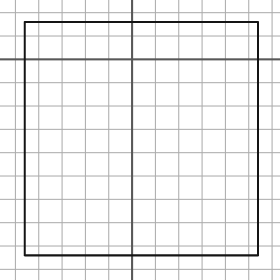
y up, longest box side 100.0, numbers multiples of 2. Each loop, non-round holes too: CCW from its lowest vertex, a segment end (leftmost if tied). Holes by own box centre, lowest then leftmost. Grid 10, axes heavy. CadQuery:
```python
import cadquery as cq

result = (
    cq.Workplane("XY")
    .moveTo(-46.0, -84.0)
    .lineTo(54.0, -84.0)
    .lineTo(54.0, 16.0)
    .lineTo(-46.0, 16.0)
    .close()
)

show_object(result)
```